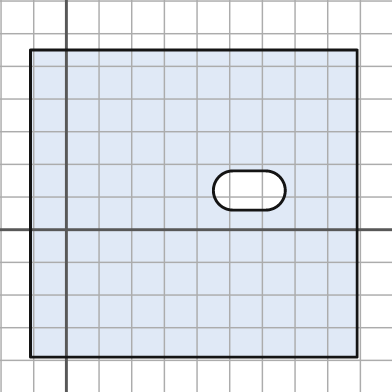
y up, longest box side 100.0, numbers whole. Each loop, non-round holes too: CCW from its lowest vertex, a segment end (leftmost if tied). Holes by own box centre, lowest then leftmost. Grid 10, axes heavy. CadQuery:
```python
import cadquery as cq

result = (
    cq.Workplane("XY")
    .moveTo(-11.0, -39.0)
    .lineTo(89.0, -39.0)
    .lineTo(89.0, 55.0)
    .lineTo(-11.0, 55.0)
    .close()
    .moveTo(51.0, 6.0)
    .lineTo(61.0, 6.0)
    .threePointArc((67.0, 12.0), (61.0, 18.0))
    .lineTo(51.0, 18.0)
    .threePointArc((45.0, 12.0), (51.0, 6.0))
    .close()
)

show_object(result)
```